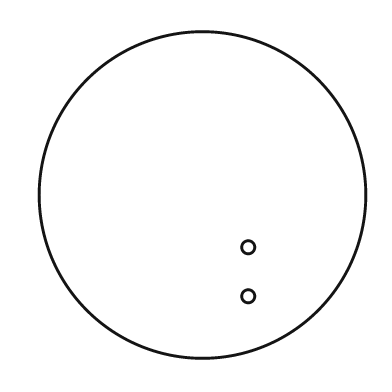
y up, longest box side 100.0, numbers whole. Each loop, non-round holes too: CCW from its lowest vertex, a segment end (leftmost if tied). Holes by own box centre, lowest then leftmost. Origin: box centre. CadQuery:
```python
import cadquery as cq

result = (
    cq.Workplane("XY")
    .moveTo(0.0, 0.0)
    .circle(50.0)
    .moveTo(14.0, -31.0)
    .circle(2.0)
    .moveTo(14.0, -16.0)
    .circle(2.0)
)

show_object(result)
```